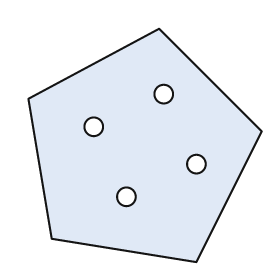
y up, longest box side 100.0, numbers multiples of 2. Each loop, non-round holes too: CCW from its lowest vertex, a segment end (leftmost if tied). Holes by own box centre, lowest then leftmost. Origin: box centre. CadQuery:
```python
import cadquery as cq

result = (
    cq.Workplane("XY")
    .moveTo(22.0, -50.0)
    .lineTo(50.0, 6.0)
    .lineTo(6.0, 50.0)
    .lineTo(-50.0, 20.0)
    .lineTo(-40.0, -40.0)
    .close()
    .moveTo(-8.0, -22.0)
    .circle(4.0)
    .moveTo(22.0, -8.0)
    .circle(4.0)
    .moveTo(-22.0, 8.0)
    .circle(4.0)
    .moveTo(8.0, 22.0)
    .circle(4.0)
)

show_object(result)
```